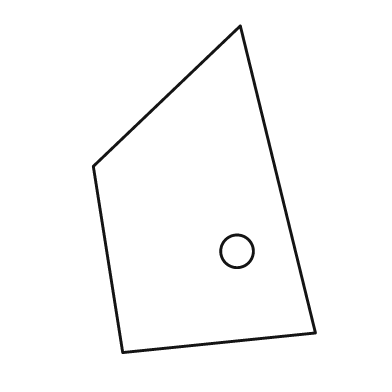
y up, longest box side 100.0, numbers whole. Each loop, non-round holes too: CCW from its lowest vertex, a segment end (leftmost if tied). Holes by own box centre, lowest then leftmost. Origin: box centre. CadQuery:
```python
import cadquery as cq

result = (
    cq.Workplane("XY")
    .moveTo(-25.0, -50.0)
    .lineTo(34.0, -44.0)
    .lineTo(11.0, 50.0)
    .lineTo(-34.0, 7.0)
    .close()
    .moveTo(10.0, -19.0)
    .circle(5.0)
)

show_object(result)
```